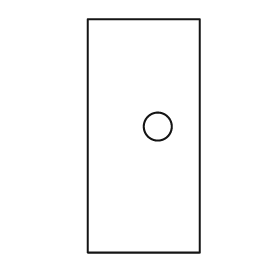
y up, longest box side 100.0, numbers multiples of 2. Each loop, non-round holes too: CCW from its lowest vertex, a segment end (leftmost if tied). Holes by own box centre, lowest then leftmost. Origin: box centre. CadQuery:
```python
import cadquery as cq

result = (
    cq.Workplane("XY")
    .moveTo(-24.0, -50.0)
    .lineTo(24.0, -50.0)
    .lineTo(24.0, 50.0)
    .lineTo(-24.0, 50.0)
    .close()
    .moveTo(6.0, 4.0)
    .circle(6.0)
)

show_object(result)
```